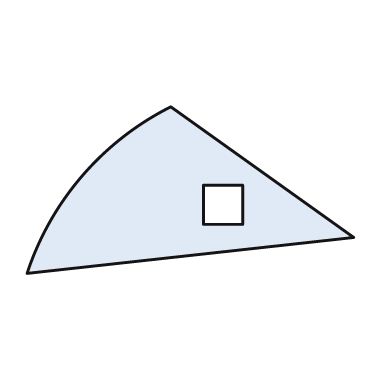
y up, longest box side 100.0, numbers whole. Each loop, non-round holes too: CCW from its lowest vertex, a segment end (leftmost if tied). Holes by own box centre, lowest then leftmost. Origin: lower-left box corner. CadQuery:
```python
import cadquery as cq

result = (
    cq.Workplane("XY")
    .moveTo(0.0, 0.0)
    .lineTo(100.0, 11.0)
    .lineTo(44.0, 51.0)
    .threePointArc((17.0, 30.0), (0.0, 0.0))
    .close()
    .moveTo(54.0, 15.0)
    .lineTo(66.0, 15.0)
    .lineTo(66.0, 27.0)
    .lineTo(54.0, 27.0)
    .close()
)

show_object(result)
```